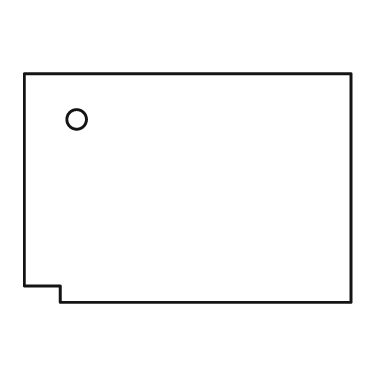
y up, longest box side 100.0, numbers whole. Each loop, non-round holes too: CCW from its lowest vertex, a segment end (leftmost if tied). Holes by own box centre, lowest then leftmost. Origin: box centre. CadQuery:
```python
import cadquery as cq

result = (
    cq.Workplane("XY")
    .moveTo(-39.0, -35.0)
    .lineTo(50.0, -35.0)
    .lineTo(50.0, 35.0)
    .lineTo(-50.0, 35.0)
    .lineTo(-50.0, -30.0)
    .lineTo(-39.0, -30.0)
    .close()
    .moveTo(-34.0, 21.0)
    .circle(3.0)
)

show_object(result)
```